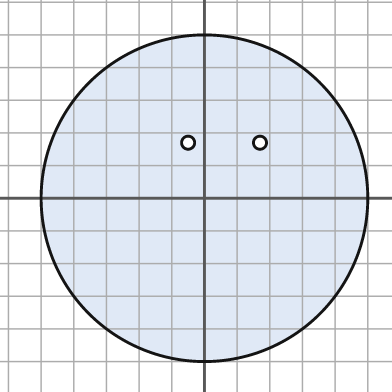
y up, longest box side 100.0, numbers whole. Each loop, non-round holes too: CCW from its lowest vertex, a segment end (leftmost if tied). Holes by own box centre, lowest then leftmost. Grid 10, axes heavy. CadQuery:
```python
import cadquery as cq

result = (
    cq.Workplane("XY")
    .moveTo(0.0, 0.0)
    .circle(50.0)
    .moveTo(-5.0, 17.0)
    .circle(2.0)
    .moveTo(17.0, 17.0)
    .circle(2.0)
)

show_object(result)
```